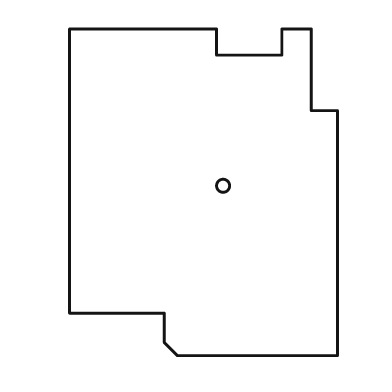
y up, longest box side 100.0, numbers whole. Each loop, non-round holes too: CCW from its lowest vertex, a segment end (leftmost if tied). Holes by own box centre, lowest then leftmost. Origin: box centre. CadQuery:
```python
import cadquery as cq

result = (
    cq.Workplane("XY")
    .moveTo(-8.0, -50.0)
    .lineTo(41.0, -50.0)
    .lineTo(41.0, 25.0)
    .lineTo(33.0, 25.0)
    .lineTo(33.0, 50.0)
    .lineTo(24.0, 50.0)
    .lineTo(24.0, 42.0)
    .lineTo(4.0, 42.0)
    .lineTo(4.0, 50.0)
    .lineTo(-41.0, 50.0)
    .lineTo(-41.0, -37.0)
    .lineTo(-12.0, -37.0)
    .lineTo(-12.0, -46.0)
    .close()
    .moveTo(6.0, 2.0)
    .circle(2.0)
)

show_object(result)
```